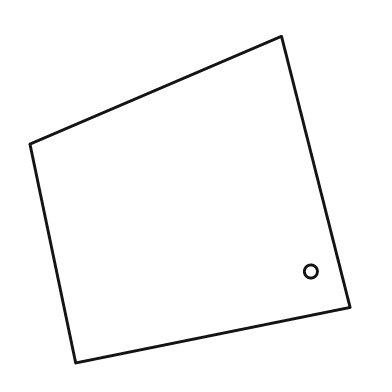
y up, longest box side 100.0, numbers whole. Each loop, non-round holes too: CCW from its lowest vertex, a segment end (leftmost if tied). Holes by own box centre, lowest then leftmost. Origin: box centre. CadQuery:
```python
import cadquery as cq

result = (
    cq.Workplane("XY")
    .moveTo(-35.0, -50.0)
    .lineTo(49.0, -33.0)
    .lineTo(28.0, 50.0)
    .lineTo(-49.0, 17.0)
    .close()
    .moveTo(37.0, -22.0)
    .circle(2.0)
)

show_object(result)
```